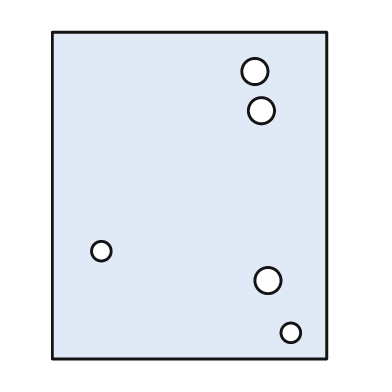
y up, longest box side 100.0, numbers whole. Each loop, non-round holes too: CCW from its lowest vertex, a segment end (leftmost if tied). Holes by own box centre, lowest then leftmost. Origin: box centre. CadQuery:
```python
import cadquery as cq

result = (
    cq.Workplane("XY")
    .moveTo(-42.0, -50.0)
    .lineTo(42.0, -50.0)
    .lineTo(42.0, 50.0)
    .lineTo(-42.0, 50.0)
    .close()
    .moveTo(31.0, -42.0)
    .circle(3.0)
    .moveTo(24.0, -26.0)
    .circle(4.0)
    .moveTo(-27.0, -17.0)
    .circle(3.0)
    .moveTo(22.0, 26.0)
    .circle(4.0)
    .moveTo(20.0, 38.0)
    .circle(4.0)
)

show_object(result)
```